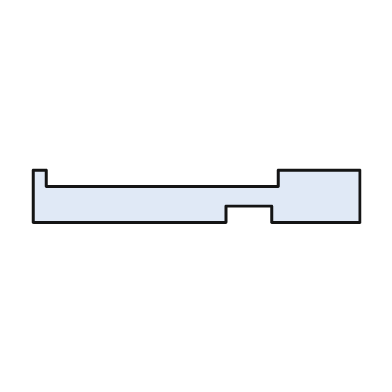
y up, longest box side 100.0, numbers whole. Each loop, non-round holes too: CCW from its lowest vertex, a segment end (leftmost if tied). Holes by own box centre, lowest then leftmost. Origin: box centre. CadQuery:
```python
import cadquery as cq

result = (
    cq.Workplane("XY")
    .moveTo(-50.0, -8.0)
    .lineTo(9.0, -8.0)
    .lineTo(9.0, -3.0)
    .lineTo(23.0, -3.0)
    .lineTo(23.0, -8.0)
    .lineTo(50.0, -8.0)
    .lineTo(50.0, 8.0)
    .lineTo(25.0, 8.0)
    .lineTo(25.0, 3.0)
    .lineTo(-46.0, 3.0)
    .lineTo(-46.0, 8.0)
    .lineTo(-50.0, 8.0)
    .close()
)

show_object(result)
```